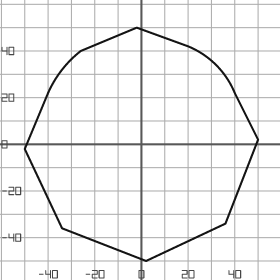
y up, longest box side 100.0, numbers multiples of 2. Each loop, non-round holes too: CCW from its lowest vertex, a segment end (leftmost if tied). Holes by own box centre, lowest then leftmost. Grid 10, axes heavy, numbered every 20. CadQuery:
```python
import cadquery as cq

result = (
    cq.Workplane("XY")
    .moveTo(2.0, -50.0)
    .lineTo(36.0, -34.0)
    .lineTo(50.0, 2.0)
    .lineTo(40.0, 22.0)
    .threePointArc((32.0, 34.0), (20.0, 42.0))
    .lineTo(-2.0, 50.0)
    .lineTo(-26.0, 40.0)
    .threePointArc((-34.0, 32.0), (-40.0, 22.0))
    .lineTo(-50.0, -2.0)
    .lineTo(-34.0, -36.0)
    .close()
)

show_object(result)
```